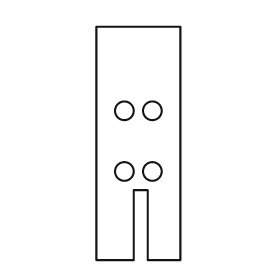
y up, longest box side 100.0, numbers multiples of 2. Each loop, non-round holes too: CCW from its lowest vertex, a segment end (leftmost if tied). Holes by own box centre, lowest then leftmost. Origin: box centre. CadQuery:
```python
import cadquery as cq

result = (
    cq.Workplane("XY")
    .moveTo(-18.0, -50.0)
    .lineTo(-2.0, -50.0)
    .lineTo(-2.0, -20.0)
    .lineTo(4.0, -20.0)
    .lineTo(4.0, -50.0)
    .lineTo(18.0, -50.0)
    .lineTo(18.0, 50.0)
    .lineTo(-18.0, 50.0)
    .close()
    .moveTo(-6.0, -12.0)
    .circle(4.0)
    .moveTo(6.0, -12.0)
    .circle(4.0)
    .moveTo(-6.0, 14.0)
    .circle(4.0)
    .moveTo(6.0, 14.0)
    .circle(4.0)
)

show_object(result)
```